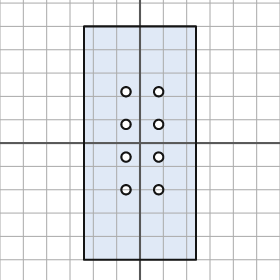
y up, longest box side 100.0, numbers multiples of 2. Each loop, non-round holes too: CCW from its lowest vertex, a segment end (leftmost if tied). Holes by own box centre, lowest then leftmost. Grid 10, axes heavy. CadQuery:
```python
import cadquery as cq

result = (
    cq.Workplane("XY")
    .moveTo(-24.0, -50.0)
    .lineTo(24.0, -50.0)
    .lineTo(24.0, 50.0)
    .lineTo(-24.0, 50.0)
    .close()
    .moveTo(-6.0, -20.0)
    .circle(2.0)
    .moveTo(8.0, -20.0)
    .circle(2.0)
    .moveTo(-6.0, -6.0)
    .circle(2.0)
    .moveTo(8.0, -6.0)
    .circle(2.0)
    .moveTo(-6.0, 8.0)
    .circle(2.0)
    .moveTo(8.0, 8.0)
    .circle(2.0)
    .moveTo(-6.0, 22.0)
    .circle(2.0)
    .moveTo(8.0, 22.0)
    .circle(2.0)
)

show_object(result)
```